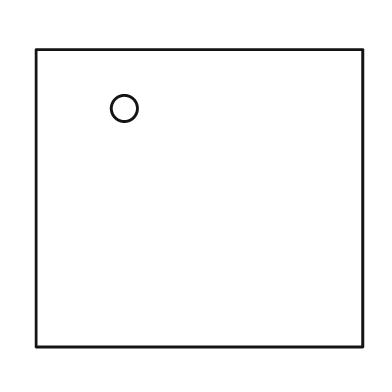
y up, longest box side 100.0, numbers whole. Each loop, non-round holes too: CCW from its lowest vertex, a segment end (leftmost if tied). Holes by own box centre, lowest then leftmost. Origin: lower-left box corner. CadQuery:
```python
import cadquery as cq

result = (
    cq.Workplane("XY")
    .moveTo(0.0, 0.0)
    .lineTo(100.0, 0.0)
    .lineTo(100.0, 91.0)
    .lineTo(0.0, 91.0)
    .close()
    .moveTo(27.0, 73.0)
    .circle(4.0)
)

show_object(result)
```